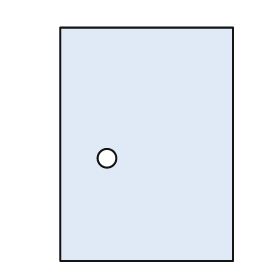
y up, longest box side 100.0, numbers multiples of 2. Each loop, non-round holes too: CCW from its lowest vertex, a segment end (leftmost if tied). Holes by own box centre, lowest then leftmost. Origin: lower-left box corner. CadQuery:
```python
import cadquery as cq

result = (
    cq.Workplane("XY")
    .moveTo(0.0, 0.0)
    .lineTo(74.0, 0.0)
    .lineTo(74.0, 100.0)
    .lineTo(0.0, 100.0)
    .close()
    .moveTo(20.0, 44.0)
    .circle(4.0)
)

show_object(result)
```